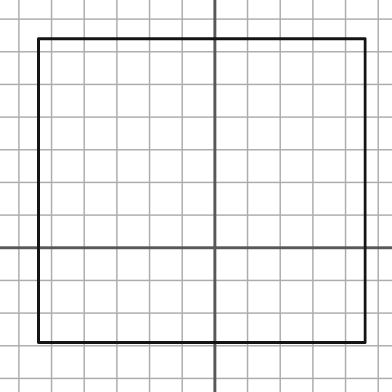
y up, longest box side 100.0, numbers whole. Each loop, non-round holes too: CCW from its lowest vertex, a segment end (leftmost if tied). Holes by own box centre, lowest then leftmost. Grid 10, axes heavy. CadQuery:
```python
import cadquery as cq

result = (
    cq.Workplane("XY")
    .moveTo(-54.0, -29.0)
    .lineTo(46.0, -29.0)
    .lineTo(46.0, 64.0)
    .lineTo(-54.0, 64.0)
    .close()
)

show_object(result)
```